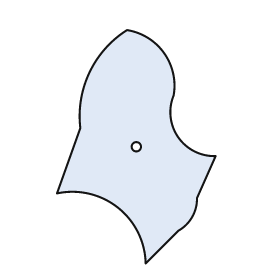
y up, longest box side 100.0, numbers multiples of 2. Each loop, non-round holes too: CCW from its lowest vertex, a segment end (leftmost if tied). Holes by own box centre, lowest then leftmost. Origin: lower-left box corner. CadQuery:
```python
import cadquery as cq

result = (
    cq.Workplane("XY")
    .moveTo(38.0, 0.0)
    .lineTo(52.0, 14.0)
    .threePointArc((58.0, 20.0), (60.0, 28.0))
    .lineTo(68.0, 46.0)
    .threePointArc((52.0, 54.0), (50.0, 72.0))
    .threePointArc((46.0, 90.0), (30.0, 100.0))
    .threePointArc((14.0, 82.0), (10.0, 58.0))
    .lineTo(0.0, 30.0)
    .threePointArc((26.0, 24.0), (38.0, 0.0))
    .close()
    .moveTo(34.0, 50.0)
    .circle(2.0)
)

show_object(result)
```